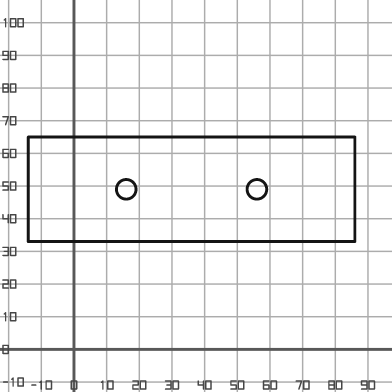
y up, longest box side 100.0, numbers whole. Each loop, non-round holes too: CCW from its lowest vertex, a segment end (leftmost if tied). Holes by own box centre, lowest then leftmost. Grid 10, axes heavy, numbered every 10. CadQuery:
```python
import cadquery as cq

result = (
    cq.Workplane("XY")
    .moveTo(-14.0, 33.0)
    .lineTo(86.0, 33.0)
    .lineTo(86.0, 65.0)
    .lineTo(-14.0, 65.0)
    .close()
    .moveTo(16.0, 49.0)
    .circle(3.0)
    .moveTo(56.0, 49.0)
    .circle(3.0)
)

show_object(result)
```